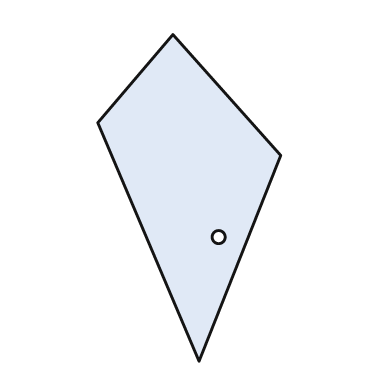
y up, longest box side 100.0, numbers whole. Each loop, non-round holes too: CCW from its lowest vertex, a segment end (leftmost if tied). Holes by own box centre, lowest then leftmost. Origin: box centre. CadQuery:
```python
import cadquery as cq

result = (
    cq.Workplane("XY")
    .moveTo(3.0, -50.0)
    .lineTo(28.0, 13.0)
    .lineTo(-5.0, 50.0)
    .lineTo(-28.0, 23.0)
    .close()
    .moveTo(9.0, -12.0)
    .circle(2.0)
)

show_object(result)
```